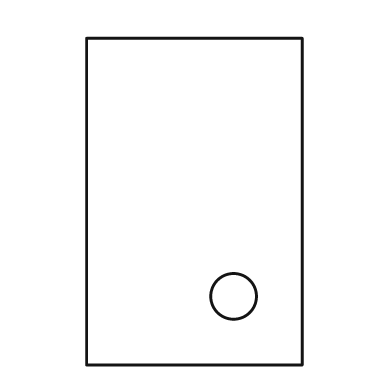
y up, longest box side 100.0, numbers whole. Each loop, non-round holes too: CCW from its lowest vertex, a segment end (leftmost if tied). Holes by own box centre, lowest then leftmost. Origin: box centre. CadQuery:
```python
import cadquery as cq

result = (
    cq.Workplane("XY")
    .moveTo(-33.0, -50.0)
    .lineTo(33.0, -50.0)
    .lineTo(33.0, 50.0)
    .lineTo(-33.0, 50.0)
    .close()
    .moveTo(12.0, -29.0)
    .circle(7.0)
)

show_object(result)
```